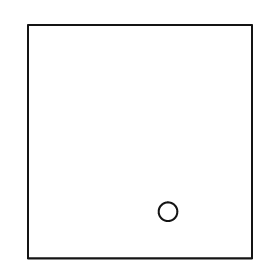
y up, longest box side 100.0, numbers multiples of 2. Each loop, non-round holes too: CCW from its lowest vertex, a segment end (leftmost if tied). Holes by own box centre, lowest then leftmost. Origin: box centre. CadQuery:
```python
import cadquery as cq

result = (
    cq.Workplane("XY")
    .moveTo(-48.0, -50.0)
    .lineTo(48.0, -50.0)
    .lineTo(48.0, 50.0)
    .lineTo(-48.0, 50.0)
    .close()
    .moveTo(12.0, -30.0)
    .circle(4.0)
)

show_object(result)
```